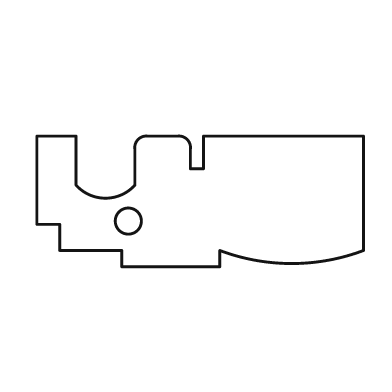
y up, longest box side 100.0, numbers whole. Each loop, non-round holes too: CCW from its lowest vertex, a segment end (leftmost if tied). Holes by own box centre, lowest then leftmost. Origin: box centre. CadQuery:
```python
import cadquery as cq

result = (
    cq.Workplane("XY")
    .moveTo(-24.0, -20.0)
    .lineTo(6.0, -20.0)
    .lineTo(6.0, -15.0)
    .threePointArc((28.0, -19.0), (50.0, -15.0))
    .lineTo(50.0, 20.0)
    .lineTo(1.0, 20.0)
    .lineTo(1.0, 10.0)
    .lineTo(-3.0, 10.0)
    .lineTo(-3.0, 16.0)
    .threePointArc((-4.0, 19.0), (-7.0, 20.0))
    .lineTo(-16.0, 20.0)
    .threePointArc((-19.0, 19.0), (-20.0, 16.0))
    .lineTo(-20.0, 5.0)
    .threePointArc((-29.0, 1.0), (-38.0, 5.0))
    .lineTo(-38.0, 20.0)
    .lineTo(-50.0, 20.0)
    .lineTo(-50.0, -7.0)
    .lineTo(-43.0, -7.0)
    .lineTo(-43.0, -15.0)
    .lineTo(-24.0, -15.0)
    .close()
    .moveTo(-22.0, -6.0)
    .circle(4.0)
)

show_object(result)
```